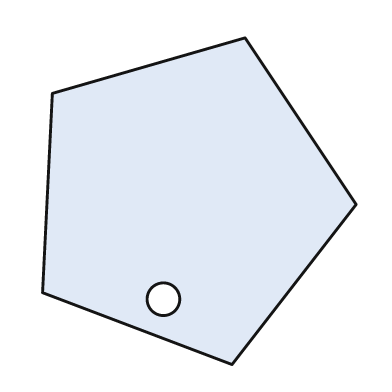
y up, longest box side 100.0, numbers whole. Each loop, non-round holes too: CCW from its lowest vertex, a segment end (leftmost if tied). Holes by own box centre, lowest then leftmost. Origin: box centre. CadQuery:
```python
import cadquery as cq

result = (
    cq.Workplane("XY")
    .moveTo(10.0, -50.0)
    .lineTo(48.0, -1.0)
    .lineTo(14.0, 50.0)
    .lineTo(-45.0, 33.0)
    .lineTo(-48.0, -28.0)
    .close()
    .moveTo(-11.0, -30.0)
    .circle(5.0)
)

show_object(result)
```